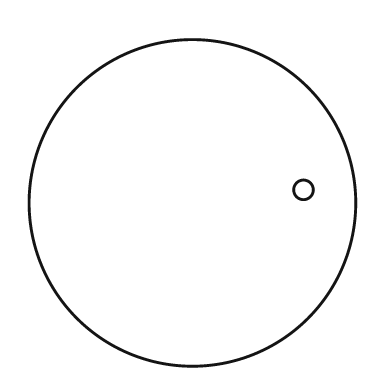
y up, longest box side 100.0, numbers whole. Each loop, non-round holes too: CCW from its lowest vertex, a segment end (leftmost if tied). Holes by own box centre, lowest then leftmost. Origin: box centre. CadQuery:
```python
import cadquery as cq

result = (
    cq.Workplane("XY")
    .moveTo(0.0, 0.0)
    .circle(50.0)
    .moveTo(34.0, 4.0)
    .circle(3.0)
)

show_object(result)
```